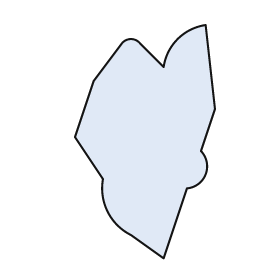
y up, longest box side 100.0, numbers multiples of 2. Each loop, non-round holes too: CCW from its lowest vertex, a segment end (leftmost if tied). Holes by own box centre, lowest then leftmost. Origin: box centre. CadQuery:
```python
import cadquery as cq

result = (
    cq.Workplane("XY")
    .moveTo(8.0, -50.0)
    .lineTo(18.0, -20.0)
    .threePointArc((26.0, -14.0), (24.0, -4.0))
    .lineTo(30.0, 14.0)
    .lineTo(26.0, 50.0)
    .threePointArc((14.0, 44.0), (8.0, 32.0))
    .lineTo(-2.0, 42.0)
    .threePointArc((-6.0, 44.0), (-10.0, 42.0))
    .lineTo(-22.0, 26.0)
    .lineTo(-30.0, 2.0)
    .lineTo(-18.0, -16.0)
    .threePointArc((-16.0, -30.0), (-6.0, -40.0))
    .close()
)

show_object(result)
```